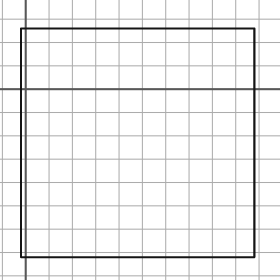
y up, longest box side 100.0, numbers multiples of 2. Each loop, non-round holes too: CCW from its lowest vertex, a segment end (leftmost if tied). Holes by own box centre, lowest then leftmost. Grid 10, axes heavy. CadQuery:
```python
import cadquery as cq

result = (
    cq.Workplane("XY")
    .moveTo(-2.0, -72.0)
    .lineTo(98.0, -72.0)
    .lineTo(98.0, 26.0)
    .lineTo(-2.0, 26.0)
    .close()
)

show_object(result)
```